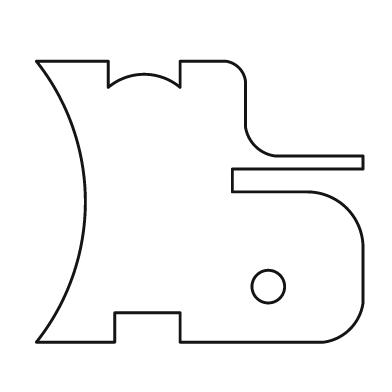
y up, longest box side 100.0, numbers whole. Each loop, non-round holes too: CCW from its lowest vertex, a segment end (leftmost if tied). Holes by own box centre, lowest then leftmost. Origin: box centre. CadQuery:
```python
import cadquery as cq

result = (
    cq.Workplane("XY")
    .moveTo(-50.0, -43.0)
    .lineTo(-26.0, -43.0)
    .lineTo(-26.0, -34.0)
    .lineTo(-6.0, -34.0)
    .lineTo(-6.0, -43.0)
    .lineTo(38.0, -43.0)
    .threePointArc((46.0, -39.0), (50.0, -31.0))
    .lineTo(50.0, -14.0)
    .threePointArc((45.0, -2.0), (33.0, 3.0))
    .lineTo(10.0, 3.0)
    .lineTo(10.0, 10.0)
    .lineTo(50.0, 10.0)
    .lineTo(50.0, 14.0)
    .lineTo(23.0, 14.0)
    .threePointArc((17.0, 17.0), (14.0, 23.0))
    .lineTo(14.0, 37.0)
    .threePointArc((12.0, 41.0), (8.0, 43.0))
    .lineTo(-6.0, 43.0)
    .lineTo(-6.0, 35.0)
    .threePointArc((-17.0, 39.0), (-28.0, 35.0))
    .lineTo(-28.0, 43.0)
    .lineTo(-50.0, 43.0)
    .threePointArc((-35.0, 0.0), (-50.0, -43.0))
    .close()
    .moveTo(21.0, -26.0)
    .circle(5.0)
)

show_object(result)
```